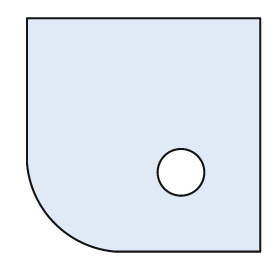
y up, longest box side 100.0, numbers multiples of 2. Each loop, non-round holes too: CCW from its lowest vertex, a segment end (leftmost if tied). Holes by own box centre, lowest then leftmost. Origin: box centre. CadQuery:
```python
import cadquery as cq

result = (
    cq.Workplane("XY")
    .moveTo(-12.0, -50.0)
    .lineTo(50.0, -50.0)
    .lineTo(50.0, 50.0)
    .lineTo(-50.0, 50.0)
    .lineTo(-50.0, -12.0)
    .threePointArc((-38.0, -38.0), (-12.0, -50.0))
    .close()
    .moveTo(16.0, -16.0)
    .circle(10.0)
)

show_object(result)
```